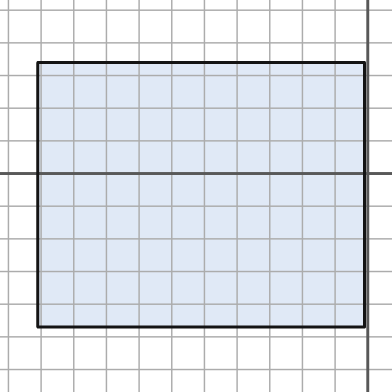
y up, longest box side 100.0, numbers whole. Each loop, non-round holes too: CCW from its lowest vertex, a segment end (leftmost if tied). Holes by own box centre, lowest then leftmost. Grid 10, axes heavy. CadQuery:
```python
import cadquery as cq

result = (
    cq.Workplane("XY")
    .moveTo(-101.0, -47.0)
    .lineTo(-1.0, -47.0)
    .lineTo(-1.0, 34.0)
    .lineTo(-101.0, 34.0)
    .close()
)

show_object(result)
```